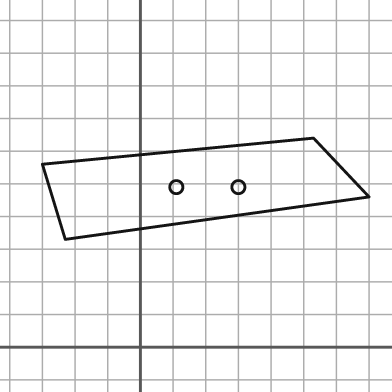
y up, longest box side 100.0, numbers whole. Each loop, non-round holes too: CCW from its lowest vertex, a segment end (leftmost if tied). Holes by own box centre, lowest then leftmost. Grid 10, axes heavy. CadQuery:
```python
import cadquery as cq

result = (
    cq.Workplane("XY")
    .moveTo(-23.0, 33.0)
    .lineTo(70.0, 46.0)
    .lineTo(53.0, 64.0)
    .lineTo(-30.0, 56.0)
    .close()
    .moveTo(11.0, 49.0)
    .circle(2.0)
    .moveTo(30.0, 49.0)
    .circle(2.0)
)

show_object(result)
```